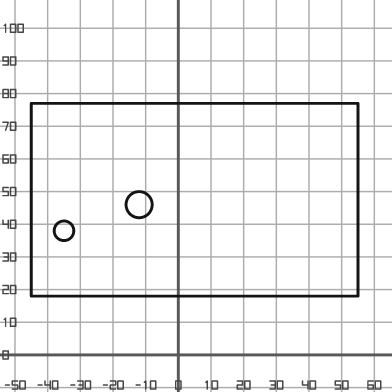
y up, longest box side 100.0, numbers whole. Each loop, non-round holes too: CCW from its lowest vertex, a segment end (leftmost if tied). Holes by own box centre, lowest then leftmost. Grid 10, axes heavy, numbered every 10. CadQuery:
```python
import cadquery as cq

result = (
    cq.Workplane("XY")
    .moveTo(-45.0, 18.0)
    .lineTo(55.0, 18.0)
    .lineTo(55.0, 77.0)
    .lineTo(-45.0, 77.0)
    .close()
    .moveTo(-35.0, 38.0)
    .circle(3.0)
    .moveTo(-12.0, 46.0)
    .circle(4.0)
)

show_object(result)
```